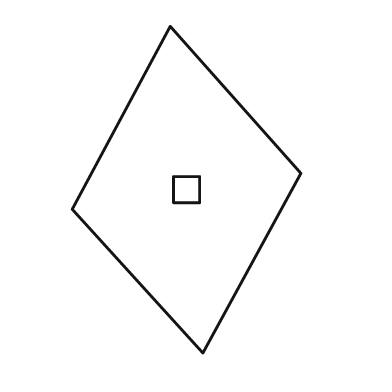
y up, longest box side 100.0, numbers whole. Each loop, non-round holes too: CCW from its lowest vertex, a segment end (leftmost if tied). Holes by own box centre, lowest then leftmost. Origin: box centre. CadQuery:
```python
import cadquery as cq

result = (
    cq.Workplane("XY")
    .moveTo(5.0, -50.0)
    .lineTo(35.0, 5.0)
    .lineTo(-5.0, 50.0)
    .lineTo(-35.0, -6.0)
    .close()
    .moveTo(-4.0, -4.0)
    .lineTo(4.0, -4.0)
    .lineTo(4.0, 4.0)
    .lineTo(-4.0, 4.0)
    .close()
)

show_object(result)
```